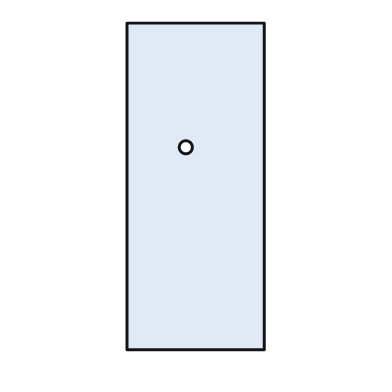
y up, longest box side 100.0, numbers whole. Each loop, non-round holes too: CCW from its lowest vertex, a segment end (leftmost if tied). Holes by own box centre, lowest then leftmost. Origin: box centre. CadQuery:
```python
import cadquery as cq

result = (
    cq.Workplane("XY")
    .moveTo(-21.0, -50.0)
    .lineTo(21.0, -50.0)
    .lineTo(21.0, 50.0)
    .lineTo(-21.0, 50.0)
    .close()
    .moveTo(-3.0, 12.0)
    .circle(2.0)
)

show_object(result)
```